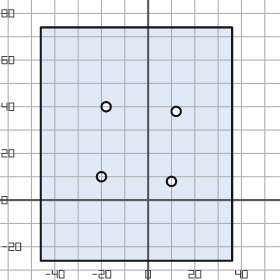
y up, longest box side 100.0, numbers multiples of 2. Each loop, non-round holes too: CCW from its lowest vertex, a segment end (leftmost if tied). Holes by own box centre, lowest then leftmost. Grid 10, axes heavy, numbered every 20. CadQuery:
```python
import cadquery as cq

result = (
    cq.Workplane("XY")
    .moveTo(-46.0, -26.0)
    .lineTo(36.0, -26.0)
    .lineTo(36.0, 74.0)
    .lineTo(-46.0, 74.0)
    .close()
    .moveTo(10.0, 8.0)
    .circle(2.0)
    .moveTo(-20.0, 10.0)
    .circle(2.0)
    .moveTo(12.0, 38.0)
    .circle(2.0)
    .moveTo(-18.0, 40.0)
    .circle(2.0)
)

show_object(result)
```